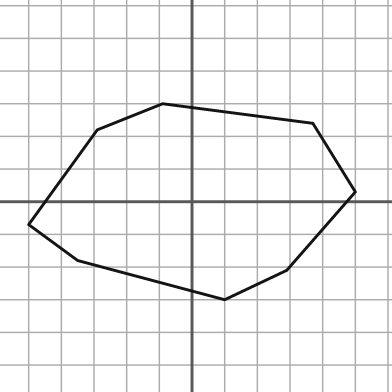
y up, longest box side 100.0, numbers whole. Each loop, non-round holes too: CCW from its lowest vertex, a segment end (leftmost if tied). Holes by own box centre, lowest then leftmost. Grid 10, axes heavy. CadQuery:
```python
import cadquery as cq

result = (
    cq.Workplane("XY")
    .moveTo(10.0, -30.0)
    .lineTo(29.0, -21.0)
    .lineTo(50.0, 3.0)
    .lineTo(37.0, 24.0)
    .lineTo(-9.0, 30.0)
    .lineTo(-29.0, 22.0)
    .lineTo(-50.0, -7.0)
    .lineTo(-35.0, -18.0)
    .close()
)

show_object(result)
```